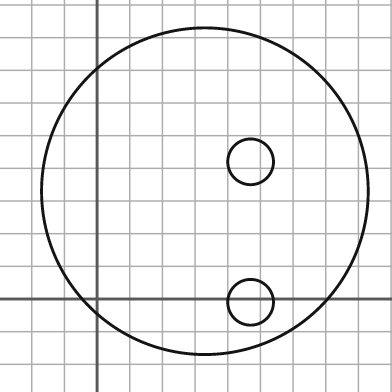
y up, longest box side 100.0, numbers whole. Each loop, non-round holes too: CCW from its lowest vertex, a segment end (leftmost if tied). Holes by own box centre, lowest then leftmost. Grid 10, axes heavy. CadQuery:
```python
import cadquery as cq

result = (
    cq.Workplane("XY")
    .moveTo(33.0, 33.0)
    .circle(50.0)
    .moveTo(47.0, -1.0)
    .circle(7.0)
    .moveTo(47.0, 42.0)
    .circle(7.0)
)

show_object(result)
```